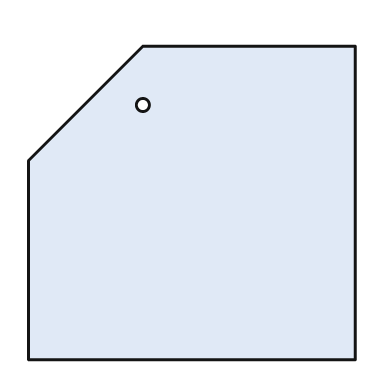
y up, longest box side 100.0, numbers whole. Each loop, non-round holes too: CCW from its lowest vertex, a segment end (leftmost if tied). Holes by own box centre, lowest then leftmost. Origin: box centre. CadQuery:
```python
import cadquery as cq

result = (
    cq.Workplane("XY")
    .moveTo(-50.0, -48.0)
    .lineTo(50.0, -48.0)
    .lineTo(50.0, 48.0)
    .lineTo(-15.0, 48.0)
    .lineTo(-50.0, 13.0)
    .close()
    .moveTo(-15.0, 30.0)
    .circle(2.0)
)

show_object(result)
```